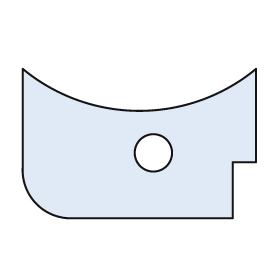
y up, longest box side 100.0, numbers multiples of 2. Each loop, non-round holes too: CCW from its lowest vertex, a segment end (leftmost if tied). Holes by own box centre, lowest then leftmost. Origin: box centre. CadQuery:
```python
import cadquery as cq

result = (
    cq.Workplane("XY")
    .moveTo(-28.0, -32.0)
    .lineTo(40.0, -32.0)
    .lineTo(40.0, -8.0)
    .lineTo(50.0, -8.0)
    .lineTo(50.0, 32.0)
    .threePointArc((0.0, 14.0), (-50.0, 32.0))
    .lineTo(-50.0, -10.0)
    .threePointArc((-44.0, -26.0), (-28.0, -32.0))
    .close()
    .moveTo(6.0, -4.0)
    .circle(8.0)
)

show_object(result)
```